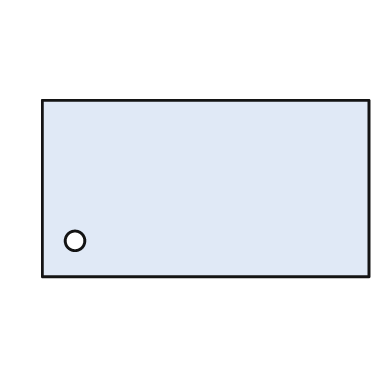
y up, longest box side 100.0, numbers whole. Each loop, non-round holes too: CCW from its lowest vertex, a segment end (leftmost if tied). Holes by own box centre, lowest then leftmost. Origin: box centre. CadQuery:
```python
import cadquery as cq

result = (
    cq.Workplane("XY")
    .moveTo(-50.0, -27.0)
    .lineTo(50.0, -27.0)
    .lineTo(50.0, 27.0)
    .lineTo(-50.0, 27.0)
    .close()
    .moveTo(-40.0, -16.0)
    .circle(3.0)
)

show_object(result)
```